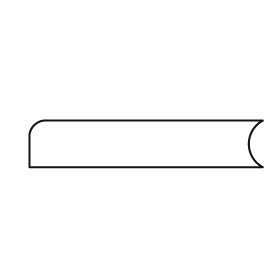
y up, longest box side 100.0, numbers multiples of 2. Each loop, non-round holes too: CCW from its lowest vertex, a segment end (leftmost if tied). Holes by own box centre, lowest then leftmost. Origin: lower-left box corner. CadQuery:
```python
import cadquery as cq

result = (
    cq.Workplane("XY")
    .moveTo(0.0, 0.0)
    .lineTo(100.0, 0.0)
    .threePointArc((94.0, 10.0), (100.0, 20.0))
    .lineTo(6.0, 20.0)
    .threePointArc((2.0, 18.0), (0.0, 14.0))
    .close()
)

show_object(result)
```